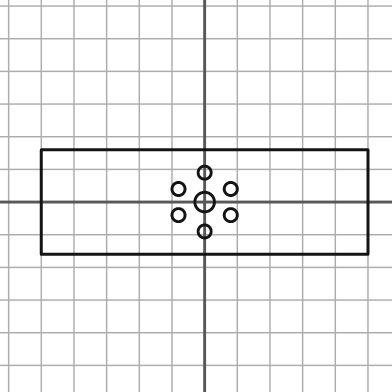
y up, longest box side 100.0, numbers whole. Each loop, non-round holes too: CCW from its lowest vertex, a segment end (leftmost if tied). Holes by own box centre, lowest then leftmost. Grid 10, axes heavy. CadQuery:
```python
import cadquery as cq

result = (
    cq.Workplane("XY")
    .moveTo(-50.0, -16.0)
    .lineTo(50.0, -16.0)
    .lineTo(50.0, 16.0)
    .lineTo(-50.0, 16.0)
    .close()
    .moveTo(0.0, -9.0)
    .circle(2.0)
    .moveTo(-8.0, -4.0)
    .circle(2.0)
    .moveTo(8.0, -4.0)
    .circle(2.0)
    .moveTo(0.0, 0.0)
    .circle(3.0)
    .moveTo(-8.0, 4.0)
    .circle(2.0)
    .moveTo(8.0, 4.0)
    .circle(2.0)
    .moveTo(0.0, 9.0)
    .circle(2.0)
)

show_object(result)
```